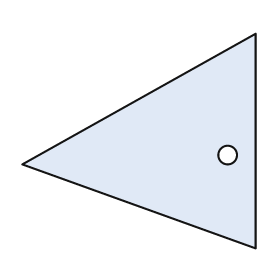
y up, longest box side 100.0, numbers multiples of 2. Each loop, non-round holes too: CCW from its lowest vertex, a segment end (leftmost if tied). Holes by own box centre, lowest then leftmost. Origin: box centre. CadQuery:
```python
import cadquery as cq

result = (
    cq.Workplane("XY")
    .moveTo(50.0, -46.0)
    .lineTo(50.0, 46.0)
    .lineTo(-50.0, -10.0)
    .close()
    .moveTo(38.0, -6.0)
    .circle(4.0)
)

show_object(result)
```